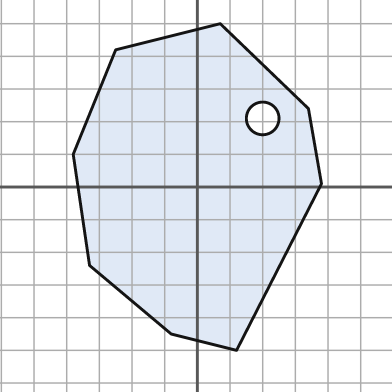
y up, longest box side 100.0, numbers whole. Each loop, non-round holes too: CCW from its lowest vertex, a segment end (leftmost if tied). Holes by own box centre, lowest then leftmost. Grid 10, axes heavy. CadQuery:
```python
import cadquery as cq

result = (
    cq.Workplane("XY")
    .moveTo(12.0, -50.0)
    .lineTo(38.0, 1.0)
    .lineTo(34.0, 24.0)
    .lineTo(7.0, 50.0)
    .lineTo(-25.0, 42.0)
    .lineTo(-38.0, 10.0)
    .lineTo(-33.0, -24.0)
    .lineTo(-8.0, -45.0)
    .close()
    .moveTo(20.0, 21.0)
    .circle(5.0)
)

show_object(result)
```